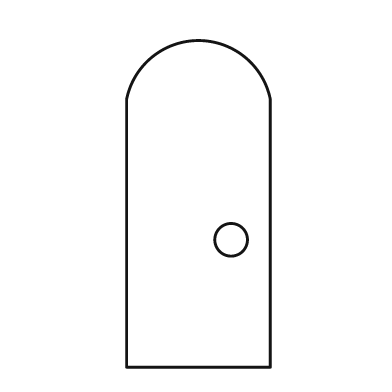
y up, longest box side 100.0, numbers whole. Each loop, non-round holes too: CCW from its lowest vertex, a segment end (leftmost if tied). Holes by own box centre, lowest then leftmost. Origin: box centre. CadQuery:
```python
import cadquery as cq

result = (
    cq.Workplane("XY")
    .moveTo(-22.0, -50.0)
    .lineTo(22.0, -50.0)
    .lineTo(22.0, 32.0)
    .threePointArc((0.0, 50.0), (-22.0, 32.0))
    .close()
    .moveTo(10.0, -11.0)
    .circle(5.0)
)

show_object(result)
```